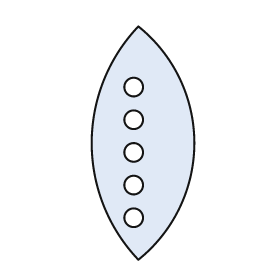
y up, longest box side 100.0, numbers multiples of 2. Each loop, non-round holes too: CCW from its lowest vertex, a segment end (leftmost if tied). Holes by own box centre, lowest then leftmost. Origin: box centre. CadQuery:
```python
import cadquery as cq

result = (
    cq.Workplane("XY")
    .moveTo(-2.0, -50.0)
    .threePointArc((22.0, 0.0), (-2.0, 50.0))
    .threePointArc((-22.0, 0.0), (-2.0, -50.0))
    .close()
    .moveTo(-4.0, -32.0)
    .circle(4.0)
    .moveTo(-4.0, -18.0)
    .circle(4.0)
    .moveTo(-4.0, -4.0)
    .circle(4.0)
    .moveTo(-4.0, 10.0)
    .circle(4.0)
    .moveTo(-4.0, 24.0)
    .circle(4.0)
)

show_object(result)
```